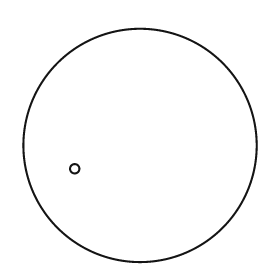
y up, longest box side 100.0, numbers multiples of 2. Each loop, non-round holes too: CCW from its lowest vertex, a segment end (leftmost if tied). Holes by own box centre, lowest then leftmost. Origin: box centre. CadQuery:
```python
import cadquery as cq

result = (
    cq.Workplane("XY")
    .moveTo(0.0, 0.0)
    .circle(50.0)
    .moveTo(-28.0, -10.0)
    .circle(2.0)
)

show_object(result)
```